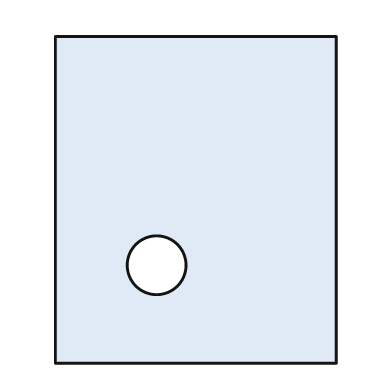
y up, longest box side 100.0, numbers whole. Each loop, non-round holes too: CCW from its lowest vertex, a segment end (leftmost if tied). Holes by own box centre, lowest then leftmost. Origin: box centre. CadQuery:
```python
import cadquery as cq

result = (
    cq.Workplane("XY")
    .moveTo(-43.0, -50.0)
    .lineTo(43.0, -50.0)
    .lineTo(43.0, 50.0)
    .lineTo(-43.0, 50.0)
    .close()
    .moveTo(-12.0, -20.0)
    .circle(9.0)
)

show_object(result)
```